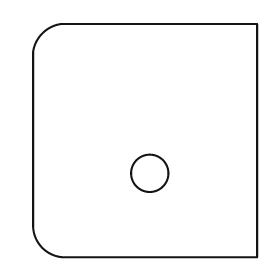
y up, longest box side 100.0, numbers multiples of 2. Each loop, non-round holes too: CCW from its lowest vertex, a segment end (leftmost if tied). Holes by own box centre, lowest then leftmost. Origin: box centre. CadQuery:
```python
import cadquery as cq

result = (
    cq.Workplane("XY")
    .moveTo(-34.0, -50.0)
    .lineTo(48.0, -50.0)
    .lineTo(48.0, 50.0)
    .lineTo(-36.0, 50.0)
    .threePointArc((-44.0, 46.0), (-48.0, 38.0))
    .lineTo(-48.0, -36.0)
    .threePointArc((-44.0, -46.0), (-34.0, -50.0))
    .close()
    .moveTo(2.0, -14.0)
    .circle(8.0)
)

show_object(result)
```